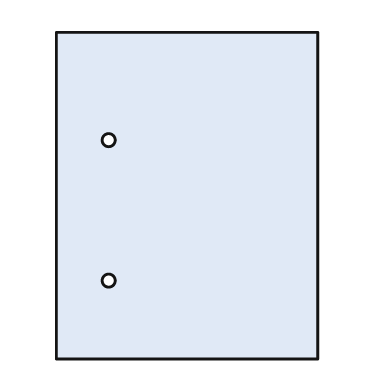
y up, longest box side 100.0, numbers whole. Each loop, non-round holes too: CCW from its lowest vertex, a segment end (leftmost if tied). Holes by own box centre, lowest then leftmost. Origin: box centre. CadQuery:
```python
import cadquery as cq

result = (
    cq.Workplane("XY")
    .moveTo(-40.0, -50.0)
    .lineTo(40.0, -50.0)
    .lineTo(40.0, 50.0)
    .lineTo(-40.0, 50.0)
    .close()
    .moveTo(-24.0, -26.0)
    .circle(2.0)
    .moveTo(-24.0, 17.0)
    .circle(2.0)
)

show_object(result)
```